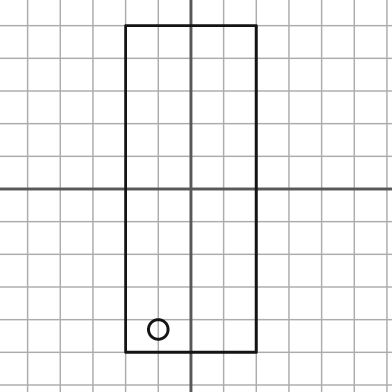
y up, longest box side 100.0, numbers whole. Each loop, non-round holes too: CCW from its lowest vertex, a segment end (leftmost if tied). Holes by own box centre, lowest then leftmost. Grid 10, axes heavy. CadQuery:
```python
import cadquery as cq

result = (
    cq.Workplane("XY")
    .moveTo(-20.0, -50.0)
    .lineTo(20.0, -50.0)
    .lineTo(20.0, 50.0)
    .lineTo(-20.0, 50.0)
    .close()
    .moveTo(-10.0, -43.0)
    .circle(3.0)
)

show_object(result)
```